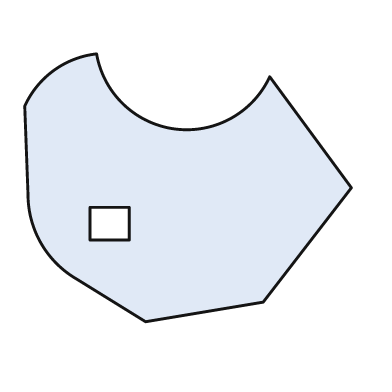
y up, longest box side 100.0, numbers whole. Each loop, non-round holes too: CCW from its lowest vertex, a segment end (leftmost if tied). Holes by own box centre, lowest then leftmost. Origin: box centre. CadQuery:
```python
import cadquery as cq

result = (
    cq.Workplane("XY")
    .moveTo(-13.0, -41.0)
    .lineTo(23.0, -35.0)
    .lineTo(50.0, 0.0)
    .lineTo(25.0, 34.0)
    .threePointArc((-4.0, 18.0), (-28.0, 41.0))
    .threePointArc((-41.0, 36.0), (-50.0, 25.0))
    .lineTo(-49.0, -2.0)
    .threePointArc((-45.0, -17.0), (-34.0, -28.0))
    .close()
    .moveTo(-30.0, -16.0)
    .lineTo(-18.0, -16.0)
    .lineTo(-18.0, -6.0)
    .lineTo(-30.0, -6.0)
    .close()
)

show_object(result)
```